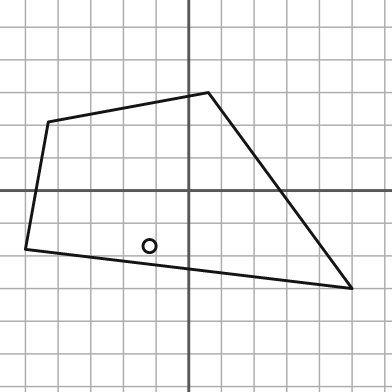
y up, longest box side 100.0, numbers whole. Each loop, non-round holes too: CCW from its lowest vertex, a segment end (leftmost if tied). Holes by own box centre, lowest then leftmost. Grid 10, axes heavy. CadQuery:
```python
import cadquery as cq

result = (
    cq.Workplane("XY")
    .moveTo(50.0, -30.0)
    .lineTo(6.0, 30.0)
    .lineTo(-43.0, 21.0)
    .lineTo(-50.0, -18.0)
    .close()
    .moveTo(-12.0, -17.0)
    .circle(2.0)
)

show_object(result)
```